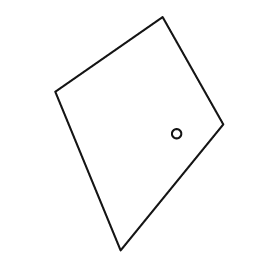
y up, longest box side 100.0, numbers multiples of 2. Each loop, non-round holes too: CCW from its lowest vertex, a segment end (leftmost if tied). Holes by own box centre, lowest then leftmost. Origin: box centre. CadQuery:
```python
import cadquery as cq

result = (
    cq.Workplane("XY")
    .moveTo(-8.0, -50.0)
    .lineTo(36.0, 4.0)
    .lineTo(10.0, 50.0)
    .lineTo(-36.0, 18.0)
    .close()
    .moveTo(16.0, 0.0)
    .circle(2.0)
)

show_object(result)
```